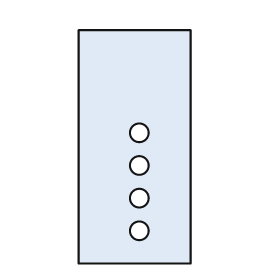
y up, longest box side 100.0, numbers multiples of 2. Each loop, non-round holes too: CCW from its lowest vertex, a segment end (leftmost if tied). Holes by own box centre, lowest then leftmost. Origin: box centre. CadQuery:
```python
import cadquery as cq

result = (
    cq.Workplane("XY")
    .moveTo(-24.0, -50.0)
    .lineTo(24.0, -50.0)
    .lineTo(24.0, 50.0)
    .lineTo(-24.0, 50.0)
    .close()
    .moveTo(2.0, -36.0)
    .circle(4.0)
    .moveTo(2.0, -22.0)
    .circle(4.0)
    .moveTo(2.0, -8.0)
    .circle(4.0)
    .moveTo(2.0, 6.0)
    .circle(4.0)
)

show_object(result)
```